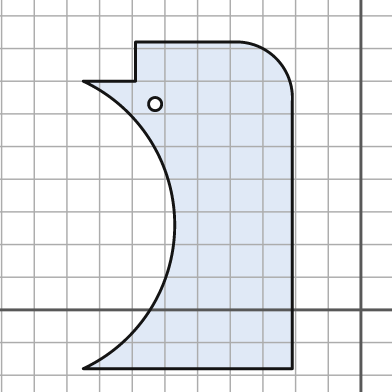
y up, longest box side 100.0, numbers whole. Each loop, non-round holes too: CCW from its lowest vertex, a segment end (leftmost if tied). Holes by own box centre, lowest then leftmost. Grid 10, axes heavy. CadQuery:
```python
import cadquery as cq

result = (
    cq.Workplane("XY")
    .moveTo(-85.0, -18.0)
    .lineTo(-21.0, -18.0)
    .lineTo(-21.0, 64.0)
    .threePointArc((-26.0, 77.0), (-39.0, 82.0))
    .lineTo(-69.0, 82.0)
    .lineTo(-69.0, 70.0)
    .lineTo(-85.0, 70.0)
    .threePointArc((-57.0, 26.0), (-85.0, -18.0))
    .close()
    .moveTo(-63.0, 63.0)
    .circle(2.0)
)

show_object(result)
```